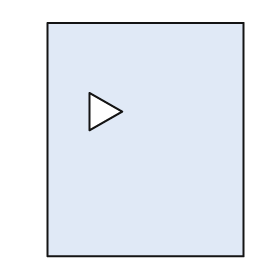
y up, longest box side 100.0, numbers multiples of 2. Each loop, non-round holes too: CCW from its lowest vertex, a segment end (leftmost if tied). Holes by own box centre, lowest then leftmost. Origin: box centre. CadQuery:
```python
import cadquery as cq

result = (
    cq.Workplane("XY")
    .moveTo(-42.0, -50.0)
    .lineTo(42.0, -50.0)
    .lineTo(42.0, 50.0)
    .lineTo(-42.0, 50.0)
    .close()
    .moveTo(-24.0, 4.0)
    .lineTo(-10.0, 12.0)
    .lineTo(-24.0, 20.0)
    .close()
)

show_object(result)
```